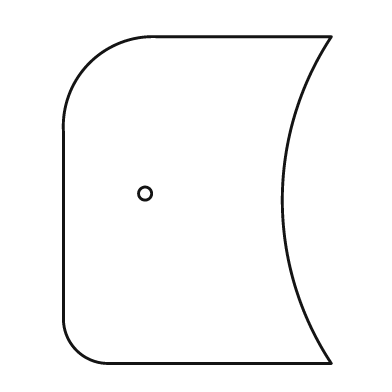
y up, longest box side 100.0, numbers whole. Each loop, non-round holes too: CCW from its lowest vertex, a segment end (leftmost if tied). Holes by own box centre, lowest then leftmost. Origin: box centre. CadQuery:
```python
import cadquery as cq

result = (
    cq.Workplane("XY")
    .moveTo(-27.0, -50.0)
    .lineTo(41.0, -50.0)
    .threePointArc((26.0, 0.0), (41.0, 50.0))
    .lineTo(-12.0, 50.0)
    .threePointArc((-33.0, 42.0), (-41.0, 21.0))
    .lineTo(-41.0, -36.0)
    .threePointArc((-37.0, -46.0), (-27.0, -50.0))
    .close()
    .moveTo(-16.0, 2.0)
    .circle(2.0)
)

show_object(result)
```